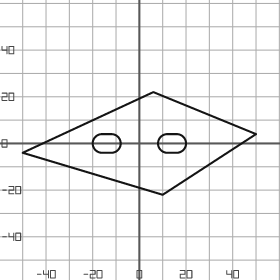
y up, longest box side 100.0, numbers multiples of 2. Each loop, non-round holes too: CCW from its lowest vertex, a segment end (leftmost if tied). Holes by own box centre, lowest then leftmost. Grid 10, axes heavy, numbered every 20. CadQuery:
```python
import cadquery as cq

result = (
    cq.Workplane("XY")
    .moveTo(10.0, -22.0)
    .lineTo(50.0, 4.0)
    .lineTo(6.0, 22.0)
    .lineTo(-50.0, -4.0)
    .close()
    .moveTo(-16.0, -4.0)
    .lineTo(-12.0, -4.0)
    .threePointArc((-8.0, 0.0), (-12.0, 4.0))
    .lineTo(-16.0, 4.0)
    .threePointArc((-20.0, 0.0), (-16.0, -4.0))
    .close()
    .moveTo(12.0, -4.0)
    .lineTo(16.0, -4.0)
    .threePointArc((20.0, 0.0), (16.0, 4.0))
    .lineTo(12.0, 4.0)
    .threePointArc((8.0, 0.0), (12.0, -4.0))
    .close()
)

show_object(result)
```